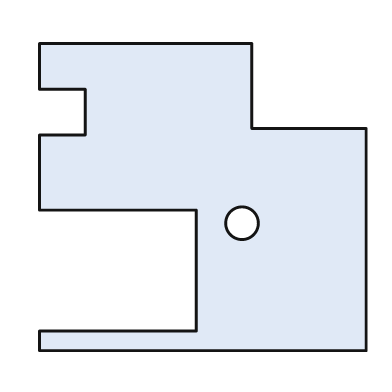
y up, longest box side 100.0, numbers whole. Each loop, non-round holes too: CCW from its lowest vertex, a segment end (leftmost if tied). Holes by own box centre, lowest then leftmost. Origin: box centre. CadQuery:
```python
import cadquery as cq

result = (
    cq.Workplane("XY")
    .moveTo(-50.0, -47.0)
    .lineTo(50.0, -47.0)
    .lineTo(50.0, 21.0)
    .lineTo(15.0, 21.0)
    .lineTo(15.0, 47.0)
    .lineTo(-50.0, 47.0)
    .lineTo(-50.0, 33.0)
    .lineTo(-36.0, 33.0)
    .lineTo(-36.0, 19.0)
    .lineTo(-50.0, 19.0)
    .lineTo(-50.0, -4.0)
    .lineTo(-2.0, -4.0)
    .lineTo(-2.0, -41.0)
    .lineTo(-50.0, -41.0)
    .close()
    .moveTo(12.0, -8.0)
    .circle(5.0)
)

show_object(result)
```